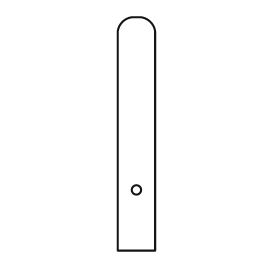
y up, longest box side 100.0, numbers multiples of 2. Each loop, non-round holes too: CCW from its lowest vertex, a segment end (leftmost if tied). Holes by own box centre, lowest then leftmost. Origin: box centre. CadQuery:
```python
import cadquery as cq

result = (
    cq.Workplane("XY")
    .moveTo(-8.0, -50.0)
    .lineTo(8.0, -50.0)
    .lineTo(8.0, 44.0)
    .threePointArc((6.0, 48.0), (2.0, 50.0))
    .lineTo(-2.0, 50.0)
    .threePointArc((-6.0, 48.0), (-8.0, 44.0))
    .close()
    .moveTo(0.0, -24.0)
    .circle(2.0)
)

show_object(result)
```